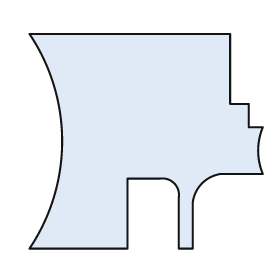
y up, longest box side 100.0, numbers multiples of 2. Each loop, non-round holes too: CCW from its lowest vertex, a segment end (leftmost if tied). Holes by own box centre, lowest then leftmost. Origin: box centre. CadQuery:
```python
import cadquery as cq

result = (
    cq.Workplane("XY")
    .moveTo(-50.0, -46.0)
    .lineTo(-8.0, -46.0)
    .lineTo(-8.0, -16.0)
    .lineTo(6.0, -16.0)
    .threePointArc((12.0, -18.0), (14.0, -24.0))
    .lineTo(14.0, -46.0)
    .lineTo(20.0, -46.0)
    .lineTo(20.0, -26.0)
    .threePointArc((24.0, -18.0), (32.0, -14.0))
    .lineTo(50.0, -14.0)
    .threePointArc((48.0, -4.0), (50.0, 6.0))
    .lineTo(44.0, 6.0)
    .lineTo(44.0, 16.0)
    .lineTo(36.0, 16.0)
    .lineTo(36.0, 46.0)
    .lineTo(-50.0, 46.0)
    .threePointArc((-36.0, 0.0), (-50.0, -46.0))
    .close()
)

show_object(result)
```